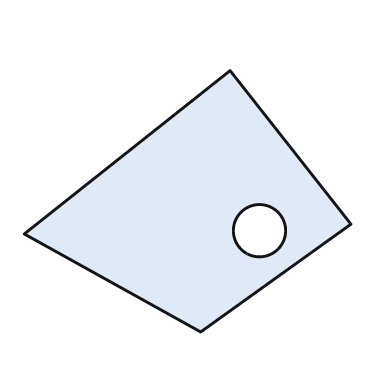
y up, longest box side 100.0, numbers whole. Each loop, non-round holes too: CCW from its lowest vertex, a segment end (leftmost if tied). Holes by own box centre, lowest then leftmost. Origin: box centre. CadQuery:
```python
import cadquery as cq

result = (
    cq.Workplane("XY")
    .moveTo(4.0, -40.0)
    .lineTo(50.0, -7.0)
    .lineTo(13.0, 40.0)
    .lineTo(-50.0, -10.0)
    .close()
    .moveTo(22.0, -9.0)
    .circle(8.0)
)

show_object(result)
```